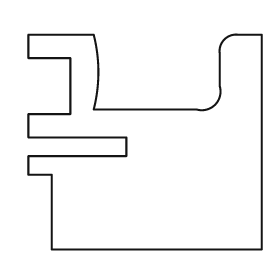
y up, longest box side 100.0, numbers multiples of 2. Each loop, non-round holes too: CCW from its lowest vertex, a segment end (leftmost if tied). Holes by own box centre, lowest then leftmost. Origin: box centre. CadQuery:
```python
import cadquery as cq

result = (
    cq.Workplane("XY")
    .moveTo(-40.0, -46.0)
    .lineTo(50.0, -46.0)
    .lineTo(50.0, 46.0)
    .lineTo(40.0, 46.0)
    .threePointArc((34.0, 44.0), (32.0, 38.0))
    .lineTo(32.0, 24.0)
    .threePointArc((30.0, 16.0), (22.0, 14.0))
    .lineTo(-22.0, 14.0)
    .threePointArc((-20.0, 30.0), (-22.0, 46.0))
    .lineTo(-50.0, 46.0)
    .lineTo(-50.0, 36.0)
    .lineTo(-32.0, 36.0)
    .lineTo(-32.0, 12.0)
    .lineTo(-50.0, 12.0)
    .lineTo(-50.0, 2.0)
    .lineTo(-8.0, 2.0)
    .lineTo(-8.0, -6.0)
    .lineTo(-50.0, -6.0)
    .lineTo(-50.0, -14.0)
    .lineTo(-40.0, -14.0)
    .close()
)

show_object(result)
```